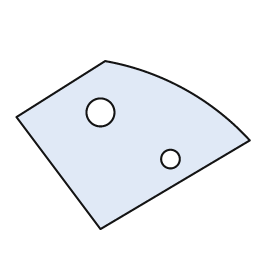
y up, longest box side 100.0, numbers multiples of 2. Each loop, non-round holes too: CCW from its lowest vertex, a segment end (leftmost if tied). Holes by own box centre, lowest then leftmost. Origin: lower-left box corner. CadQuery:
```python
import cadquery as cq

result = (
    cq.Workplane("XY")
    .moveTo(36.0, 0.0)
    .lineTo(100.0, 38.0)
    .threePointArc((72.0, 60.0), (38.0, 72.0))
    .lineTo(0.0, 48.0)
    .close()
    .moveTo(66.0, 30.0)
    .circle(4.0)
    .moveTo(36.0, 50.0)
    .circle(6.0)
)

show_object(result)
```